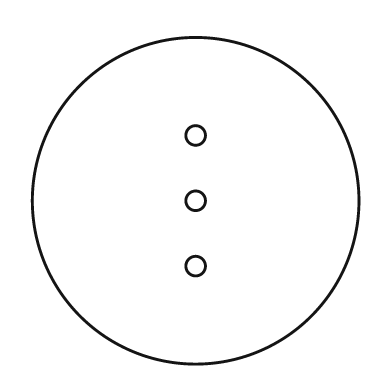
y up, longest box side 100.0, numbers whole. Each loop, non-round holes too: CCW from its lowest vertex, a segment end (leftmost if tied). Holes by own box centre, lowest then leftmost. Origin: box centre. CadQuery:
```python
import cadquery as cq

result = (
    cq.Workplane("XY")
    .moveTo(0.0, 0.0)
    .circle(50.0)
    .moveTo(0.0, -20.0)
    .circle(3.0)
    .moveTo(0.0, 0.0)
    .circle(3.0)
    .moveTo(0.0, 20.0)
    .circle(3.0)
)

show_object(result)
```